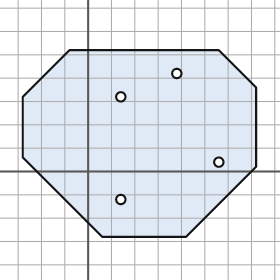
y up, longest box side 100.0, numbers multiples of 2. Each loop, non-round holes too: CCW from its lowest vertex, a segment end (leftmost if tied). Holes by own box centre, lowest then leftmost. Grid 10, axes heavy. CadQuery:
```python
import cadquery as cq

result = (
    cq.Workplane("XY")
    .moveTo(6.0, -28.0)
    .lineTo(42.0, -28.0)
    .lineTo(72.0, 2.0)
    .lineTo(72.0, 36.0)
    .lineTo(56.0, 52.0)
    .lineTo(-8.0, 52.0)
    .lineTo(-28.0, 32.0)
    .lineTo(-28.0, 6.0)
    .close()
    .moveTo(14.0, -12.0)
    .circle(2.0)
    .moveTo(56.0, 4.0)
    .circle(2.0)
    .moveTo(14.0, 32.0)
    .circle(2.0)
    .moveTo(38.0, 42.0)
    .circle(2.0)
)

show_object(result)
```